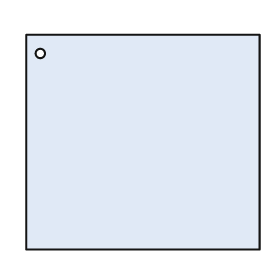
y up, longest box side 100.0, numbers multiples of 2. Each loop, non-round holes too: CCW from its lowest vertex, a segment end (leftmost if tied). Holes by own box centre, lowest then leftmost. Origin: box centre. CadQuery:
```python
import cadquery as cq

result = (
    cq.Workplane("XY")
    .moveTo(-50.0, -46.0)
    .lineTo(50.0, -46.0)
    .lineTo(50.0, 46.0)
    .lineTo(-50.0, 46.0)
    .close()
    .moveTo(-44.0, 38.0)
    .circle(2.0)
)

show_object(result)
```